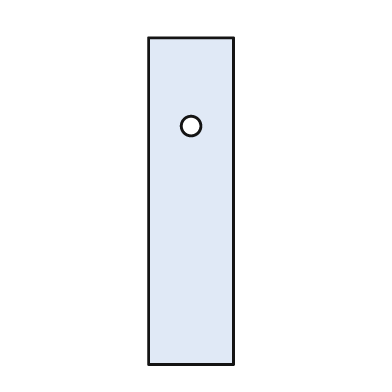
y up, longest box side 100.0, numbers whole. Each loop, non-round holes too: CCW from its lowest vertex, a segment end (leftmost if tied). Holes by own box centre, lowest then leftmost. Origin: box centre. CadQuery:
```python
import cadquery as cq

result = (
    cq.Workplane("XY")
    .moveTo(-13.0, -50.0)
    .lineTo(13.0, -50.0)
    .lineTo(13.0, 50.0)
    .lineTo(-13.0, 50.0)
    .close()
    .moveTo(0.0, 23.0)
    .circle(3.0)
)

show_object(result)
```